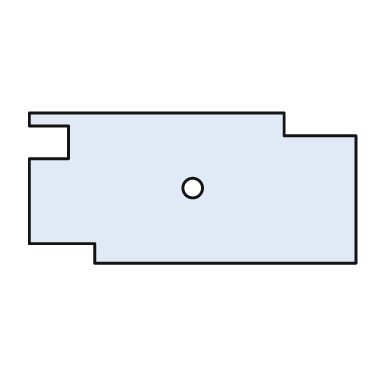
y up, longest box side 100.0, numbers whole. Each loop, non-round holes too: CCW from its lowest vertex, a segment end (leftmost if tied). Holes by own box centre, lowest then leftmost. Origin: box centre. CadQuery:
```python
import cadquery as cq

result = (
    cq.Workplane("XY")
    .moveTo(-30.0, -23.0)
    .lineTo(50.0, -23.0)
    .lineTo(50.0, 16.0)
    .lineTo(28.0, 16.0)
    .lineTo(28.0, 23.0)
    .lineTo(-50.0, 23.0)
    .lineTo(-50.0, 19.0)
    .lineTo(-38.0, 19.0)
    .lineTo(-38.0, 9.0)
    .lineTo(-50.0, 9.0)
    .lineTo(-50.0, -17.0)
    .lineTo(-30.0, -17.0)
    .close()
    .moveTo(0.0, 0.0)
    .circle(3.0)
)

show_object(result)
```